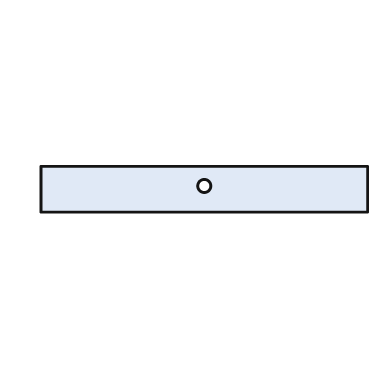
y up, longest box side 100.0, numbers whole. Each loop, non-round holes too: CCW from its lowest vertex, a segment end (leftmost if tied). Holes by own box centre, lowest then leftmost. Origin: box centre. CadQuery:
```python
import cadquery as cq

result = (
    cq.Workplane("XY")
    .moveTo(-50.0, -7.0)
    .lineTo(50.0, -7.0)
    .lineTo(50.0, 7.0)
    .lineTo(-50.0, 7.0)
    .close()
    .moveTo(0.0, 1.0)
    .circle(2.0)
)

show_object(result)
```